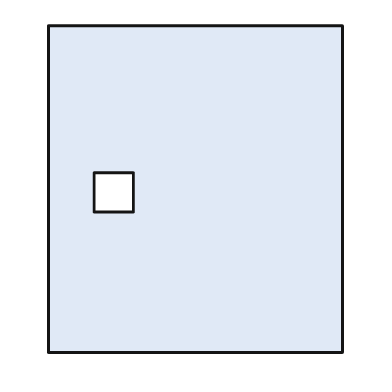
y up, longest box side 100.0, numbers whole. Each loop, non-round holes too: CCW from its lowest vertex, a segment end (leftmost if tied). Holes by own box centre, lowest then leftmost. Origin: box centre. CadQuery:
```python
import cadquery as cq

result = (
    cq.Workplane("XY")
    .moveTo(-45.0, -50.0)
    .lineTo(45.0, -50.0)
    .lineTo(45.0, 50.0)
    .lineTo(-45.0, 50.0)
    .close()
    .moveTo(-31.0, -7.0)
    .lineTo(-19.0, -7.0)
    .lineTo(-19.0, 5.0)
    .lineTo(-31.0, 5.0)
    .close()
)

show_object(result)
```